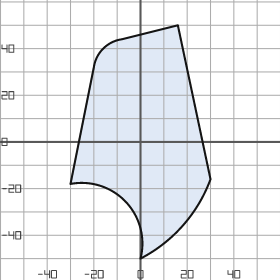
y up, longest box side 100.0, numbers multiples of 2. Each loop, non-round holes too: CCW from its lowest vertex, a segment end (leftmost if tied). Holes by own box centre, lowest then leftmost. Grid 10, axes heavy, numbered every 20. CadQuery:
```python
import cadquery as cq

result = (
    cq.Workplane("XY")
    .moveTo(0.0, -50.0)
    .threePointArc((18.0, -36.0), (30.0, -16.0))
    .lineTo(16.0, 50.0)
    .lineTo(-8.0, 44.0)
    .threePointArc((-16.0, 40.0), (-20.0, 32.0))
    .lineTo(-30.0, -18.0)
    .threePointArc((-6.0, -26.0), (0.0, -50.0))
    .close()
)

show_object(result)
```